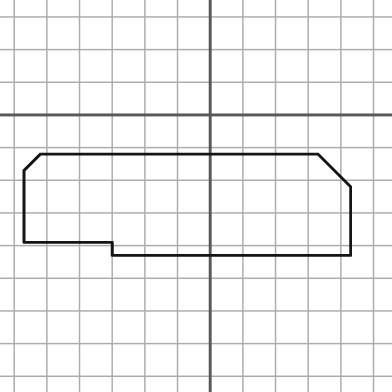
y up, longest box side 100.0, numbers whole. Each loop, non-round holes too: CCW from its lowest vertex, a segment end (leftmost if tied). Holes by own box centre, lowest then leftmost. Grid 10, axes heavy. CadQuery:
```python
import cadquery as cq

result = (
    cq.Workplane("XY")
    .moveTo(-30.0, -43.0)
    .lineTo(43.0, -43.0)
    .lineTo(43.0, -22.0)
    .lineTo(33.0, -12.0)
    .lineTo(-52.0, -12.0)
    .lineTo(-57.0, -17.0)
    .lineTo(-57.0, -39.0)
    .lineTo(-30.0, -39.0)
    .close()
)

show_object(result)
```